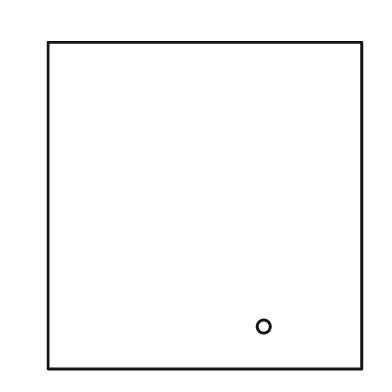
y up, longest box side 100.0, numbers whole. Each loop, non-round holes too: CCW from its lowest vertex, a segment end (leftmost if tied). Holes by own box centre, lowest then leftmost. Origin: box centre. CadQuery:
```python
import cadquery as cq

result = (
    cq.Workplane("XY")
    .moveTo(-48.0, -50.0)
    .lineTo(48.0, -50.0)
    .lineTo(48.0, 50.0)
    .lineTo(-48.0, 50.0)
    .close()
    .moveTo(18.0, -37.0)
    .circle(2.0)
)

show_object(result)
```